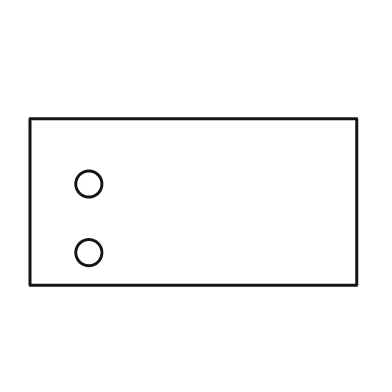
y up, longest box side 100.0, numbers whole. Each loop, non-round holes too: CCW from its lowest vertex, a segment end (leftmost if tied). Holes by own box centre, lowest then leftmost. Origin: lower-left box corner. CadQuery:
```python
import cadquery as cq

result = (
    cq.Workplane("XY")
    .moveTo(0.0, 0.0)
    .lineTo(100.0, 0.0)
    .lineTo(100.0, 51.0)
    .lineTo(0.0, 51.0)
    .close()
    .moveTo(18.0, 10.0)
    .circle(4.0)
    .moveTo(18.0, 31.0)
    .circle(4.0)
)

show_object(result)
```